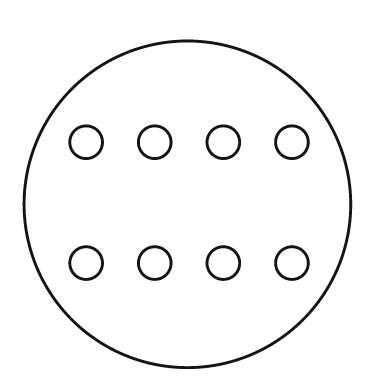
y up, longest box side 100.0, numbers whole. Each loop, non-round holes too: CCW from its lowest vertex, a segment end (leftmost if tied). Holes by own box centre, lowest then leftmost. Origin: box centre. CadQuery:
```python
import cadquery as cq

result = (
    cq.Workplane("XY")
    .moveTo(0.0, 0.0)
    .circle(50.0)
    .moveTo(-31.0, -18.0)
    .circle(5.0)
    .moveTo(-10.0, -18.0)
    .circle(5.0)
    .moveTo(11.0, -18.0)
    .circle(5.0)
    .moveTo(32.0, -18.0)
    .circle(5.0)
    .moveTo(-31.0, 19.0)
    .circle(5.0)
    .moveTo(-10.0, 19.0)
    .circle(5.0)
    .moveTo(11.0, 19.0)
    .circle(5.0)
    .moveTo(32.0, 19.0)
    .circle(5.0)
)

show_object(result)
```